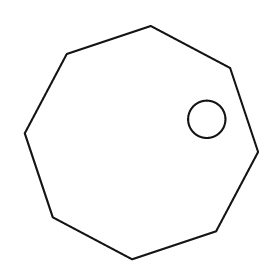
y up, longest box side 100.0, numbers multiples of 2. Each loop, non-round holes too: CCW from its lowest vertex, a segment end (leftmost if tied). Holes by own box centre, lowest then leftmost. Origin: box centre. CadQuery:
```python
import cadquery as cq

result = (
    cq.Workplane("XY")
    .moveTo(-4.0, -50.0)
    .lineTo(32.0, -38.0)
    .lineTo(50.0, -4.0)
    .lineTo(38.0, 32.0)
    .lineTo(4.0, 50.0)
    .lineTo(-32.0, 38.0)
    .lineTo(-50.0, 4.0)
    .lineTo(-38.0, -32.0)
    .close()
    .moveTo(28.0, 10.0)
    .circle(8.0)
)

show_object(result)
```